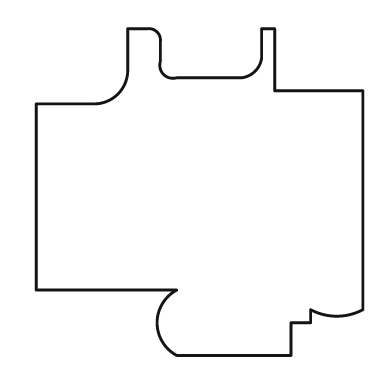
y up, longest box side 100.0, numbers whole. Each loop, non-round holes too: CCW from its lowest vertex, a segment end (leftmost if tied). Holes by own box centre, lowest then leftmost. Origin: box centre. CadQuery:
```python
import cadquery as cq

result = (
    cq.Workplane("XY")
    .moveTo(-7.0, -50.0)
    .lineTo(28.0, -50.0)
    .lineTo(28.0, -40.0)
    .lineTo(34.0, -40.0)
    .lineTo(34.0, -36.0)
    .threePointArc((42.0, -38.0), (50.0, -36.0))
    .lineTo(50.0, 31.0)
    .lineTo(23.0, 31.0)
    .lineTo(23.0, 50.0)
    .lineTo(19.0, 50.0)
    .lineTo(19.0, 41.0)
    .threePointArc((17.0, 37.0), (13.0, 35.0))
    .lineTo(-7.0, 35.0)
    .threePointArc((-11.0, 36.0), (-12.0, 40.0))
    .lineTo(-12.0, 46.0)
    .threePointArc((-13.0, 49.0), (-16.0, 50.0))
    .lineTo(-22.0, 50.0)
    .lineTo(-22.0, 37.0)
    .threePointArc((-25.0, 30.0), (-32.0, 27.0))
    .lineTo(-50.0, 27.0)
    .lineTo(-50.0, -30.0)
    .lineTo(-7.0, -30.0)
    .threePointArc((-13.0, -40.0), (-7.0, -50.0))
    .close()
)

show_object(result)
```